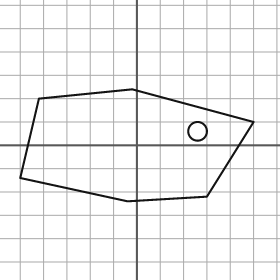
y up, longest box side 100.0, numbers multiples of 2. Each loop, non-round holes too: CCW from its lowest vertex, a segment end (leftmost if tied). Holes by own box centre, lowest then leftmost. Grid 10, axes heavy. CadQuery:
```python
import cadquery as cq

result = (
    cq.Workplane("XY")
    .moveTo(-4.0, -24.0)
    .lineTo(30.0, -22.0)
    .lineTo(50.0, 10.0)
    .lineTo(-2.0, 24.0)
    .lineTo(-42.0, 20.0)
    .lineTo(-50.0, -14.0)
    .close()
    .moveTo(26.0, 6.0)
    .circle(4.0)
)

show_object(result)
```